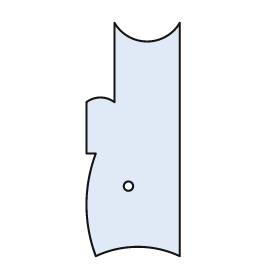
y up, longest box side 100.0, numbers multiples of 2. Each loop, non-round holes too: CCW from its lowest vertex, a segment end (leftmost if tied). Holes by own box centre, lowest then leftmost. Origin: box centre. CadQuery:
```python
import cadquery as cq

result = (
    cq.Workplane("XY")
    .moveTo(-16.0, -50.0)
    .threePointArc((2.0, -46.0), (20.0, -50.0))
    .lineTo(20.0, 50.0)
    .threePointArc((6.0, 42.0), (-8.0, 50.0))
    .lineTo(-8.0, 16.0)
    .threePointArc((-14.0, 18.0), (-20.0, 16.0))
    .lineTo(-20.0, -6.0)
    .lineTo(-16.0, -6.0)
    .threePointArc((-20.0, -28.0), (-16.0, -50.0))
    .close()
    .moveTo(-2.0, -20.0)
    .circle(2.0)
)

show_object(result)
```